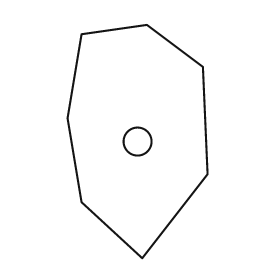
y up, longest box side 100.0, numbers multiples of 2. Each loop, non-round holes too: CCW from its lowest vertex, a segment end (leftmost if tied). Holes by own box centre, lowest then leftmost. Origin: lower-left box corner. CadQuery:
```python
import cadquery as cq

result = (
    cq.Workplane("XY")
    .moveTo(32.0, 0.0)
    .lineTo(60.0, 36.0)
    .lineTo(58.0, 82.0)
    .lineTo(34.0, 100.0)
    .lineTo(6.0, 96.0)
    .lineTo(0.0, 60.0)
    .lineTo(6.0, 24.0)
    .close()
    .moveTo(30.0, 50.0)
    .circle(6.0)
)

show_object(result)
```